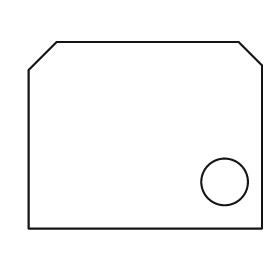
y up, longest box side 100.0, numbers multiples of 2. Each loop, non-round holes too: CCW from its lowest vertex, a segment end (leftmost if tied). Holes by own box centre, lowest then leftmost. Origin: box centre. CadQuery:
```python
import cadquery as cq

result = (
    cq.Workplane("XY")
    .moveTo(-50.0, -40.0)
    .lineTo(50.0, -40.0)
    .lineTo(50.0, 30.0)
    .lineTo(40.0, 40.0)
    .lineTo(-38.0, 40.0)
    .lineTo(-50.0, 28.0)
    .close()
    .moveTo(34.0, -20.0)
    .circle(10.0)
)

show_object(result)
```